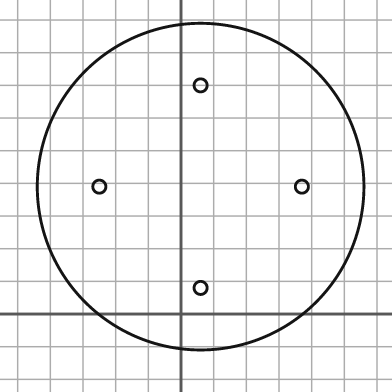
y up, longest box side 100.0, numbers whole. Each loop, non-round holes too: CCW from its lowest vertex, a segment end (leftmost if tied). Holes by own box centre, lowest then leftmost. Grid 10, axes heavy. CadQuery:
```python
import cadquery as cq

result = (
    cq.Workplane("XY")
    .moveTo(6.0, 39.0)
    .circle(50.0)
    .moveTo(6.0, 8.0)
    .circle(2.0)
    .moveTo(-25.0, 39.0)
    .circle(2.0)
    .moveTo(37.0, 39.0)
    .circle(2.0)
    .moveTo(6.0, 70.0)
    .circle(2.0)
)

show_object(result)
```